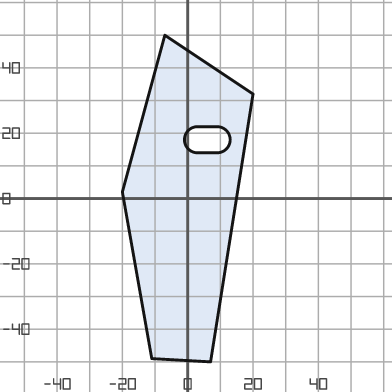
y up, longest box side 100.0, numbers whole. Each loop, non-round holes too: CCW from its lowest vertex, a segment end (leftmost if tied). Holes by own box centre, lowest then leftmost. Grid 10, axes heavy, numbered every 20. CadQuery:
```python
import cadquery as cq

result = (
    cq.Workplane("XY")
    .moveTo(7.0, -50.0)
    .lineTo(20.0, 32.0)
    .lineTo(-7.0, 50.0)
    .lineTo(-20.0, 2.0)
    .lineTo(-11.0, -49.0)
    .close()
    .moveTo(3.0, 14.0)
    .lineTo(9.0, 14.0)
    .threePointArc((13.0, 18.0), (9.0, 22.0))
    .lineTo(3.0, 22.0)
    .threePointArc((-1.0, 18.0), (3.0, 14.0))
    .close()
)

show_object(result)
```